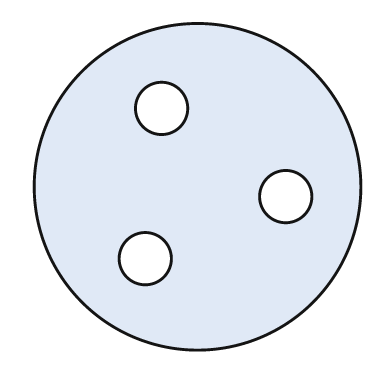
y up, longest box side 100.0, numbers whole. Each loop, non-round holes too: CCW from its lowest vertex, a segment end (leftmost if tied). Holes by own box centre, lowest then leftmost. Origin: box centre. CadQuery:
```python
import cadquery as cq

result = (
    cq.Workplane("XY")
    .moveTo(0.0, 0.0)
    .circle(50.0)
    .moveTo(-16.0, -22.0)
    .circle(8.0)
    .moveTo(27.0, -3.0)
    .circle(8.0)
    .moveTo(-11.0, 24.0)
    .circle(8.0)
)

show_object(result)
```